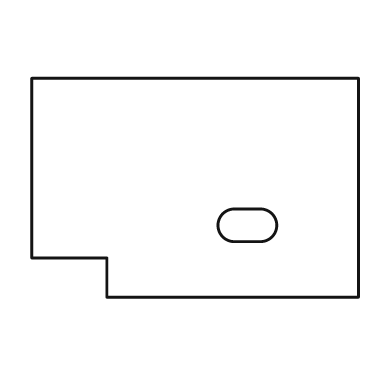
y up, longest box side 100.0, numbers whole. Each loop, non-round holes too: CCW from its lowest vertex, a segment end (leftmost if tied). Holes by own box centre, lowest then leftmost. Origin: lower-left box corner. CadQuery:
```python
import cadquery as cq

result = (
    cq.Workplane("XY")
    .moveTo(23.0, 0.0)
    .lineTo(100.0, 0.0)
    .lineTo(100.0, 67.0)
    .lineTo(0.0, 67.0)
    .lineTo(0.0, 12.0)
    .lineTo(23.0, 12.0)
    .close()
    .moveTo(62.0, 17.0)
    .lineTo(70.0, 17.0)
    .threePointArc((75.0, 22.0), (70.0, 27.0))
    .lineTo(62.0, 27.0)
    .threePointArc((57.0, 22.0), (62.0, 17.0))
    .close()
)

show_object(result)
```